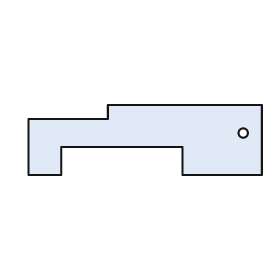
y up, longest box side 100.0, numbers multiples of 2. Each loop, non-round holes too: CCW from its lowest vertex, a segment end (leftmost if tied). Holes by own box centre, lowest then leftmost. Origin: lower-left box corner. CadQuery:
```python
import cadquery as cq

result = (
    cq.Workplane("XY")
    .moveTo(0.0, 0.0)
    .lineTo(14.0, 0.0)
    .lineTo(14.0, 12.0)
    .lineTo(66.0, 12.0)
    .lineTo(66.0, 0.0)
    .lineTo(100.0, 0.0)
    .lineTo(100.0, 30.0)
    .lineTo(34.0, 30.0)
    .lineTo(34.0, 24.0)
    .lineTo(0.0, 24.0)
    .close()
    .moveTo(92.0, 18.0)
    .circle(2.0)
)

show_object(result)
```